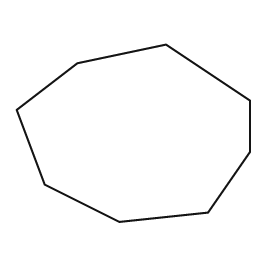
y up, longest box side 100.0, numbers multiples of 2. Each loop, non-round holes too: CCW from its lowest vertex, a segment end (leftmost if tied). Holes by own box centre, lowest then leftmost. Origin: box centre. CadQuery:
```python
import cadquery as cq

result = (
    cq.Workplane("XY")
    .moveTo(-6.0, -38.0)
    .lineTo(32.0, -34.0)
    .lineTo(50.0, -8.0)
    .lineTo(50.0, 14.0)
    .lineTo(14.0, 38.0)
    .lineTo(-24.0, 30.0)
    .lineTo(-50.0, 10.0)
    .lineTo(-38.0, -22.0)
    .close()
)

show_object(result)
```